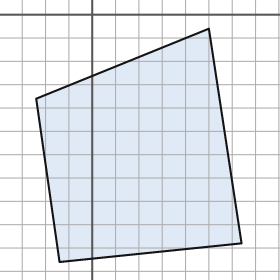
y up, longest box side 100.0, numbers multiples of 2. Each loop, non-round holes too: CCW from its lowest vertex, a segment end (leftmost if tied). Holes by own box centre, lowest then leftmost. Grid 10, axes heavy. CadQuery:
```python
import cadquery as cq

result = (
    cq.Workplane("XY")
    .moveTo(-14.0, -106.0)
    .lineTo(64.0, -98.0)
    .lineTo(50.0, -6.0)
    .lineTo(-24.0, -36.0)
    .close()
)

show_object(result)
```